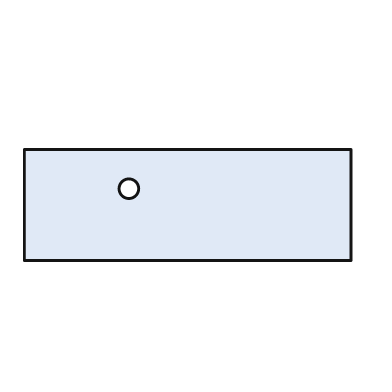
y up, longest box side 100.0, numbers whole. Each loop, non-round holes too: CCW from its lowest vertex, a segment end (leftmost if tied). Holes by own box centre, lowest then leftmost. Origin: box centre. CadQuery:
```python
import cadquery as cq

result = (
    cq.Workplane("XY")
    .moveTo(-50.0, -17.0)
    .lineTo(50.0, -17.0)
    .lineTo(50.0, 17.0)
    .lineTo(-50.0, 17.0)
    .close()
    .moveTo(-18.0, 5.0)
    .circle(3.0)
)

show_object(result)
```